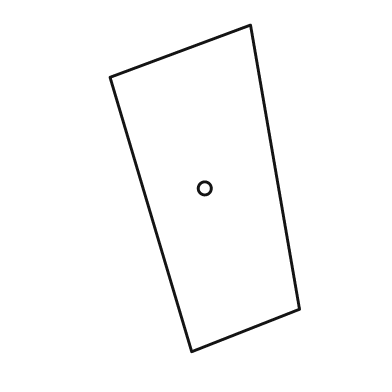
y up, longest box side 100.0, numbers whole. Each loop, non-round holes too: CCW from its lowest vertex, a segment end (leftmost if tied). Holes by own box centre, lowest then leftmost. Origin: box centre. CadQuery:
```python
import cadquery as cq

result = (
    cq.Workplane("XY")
    .moveTo(-4.0, -50.0)
    .lineTo(29.0, -37.0)
    .lineTo(14.0, 50.0)
    .lineTo(-29.0, 34.0)
    .close()
    .moveTo(0.0, 0.0)
    .circle(2.0)
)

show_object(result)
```